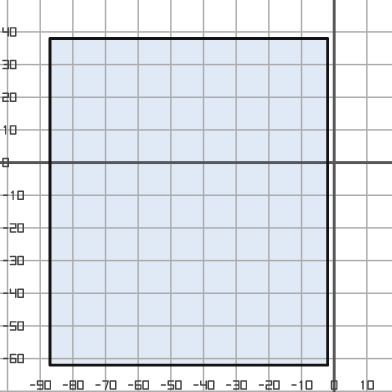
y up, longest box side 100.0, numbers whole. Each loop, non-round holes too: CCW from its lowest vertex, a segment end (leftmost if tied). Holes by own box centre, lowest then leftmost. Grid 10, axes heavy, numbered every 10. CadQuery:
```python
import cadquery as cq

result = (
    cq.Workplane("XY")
    .moveTo(-87.0, -62.0)
    .lineTo(-2.0, -62.0)
    .lineTo(-2.0, 38.0)
    .lineTo(-87.0, 38.0)
    .close()
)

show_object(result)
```